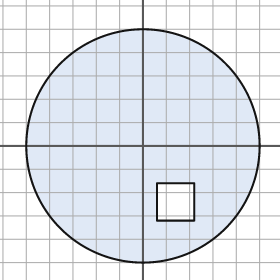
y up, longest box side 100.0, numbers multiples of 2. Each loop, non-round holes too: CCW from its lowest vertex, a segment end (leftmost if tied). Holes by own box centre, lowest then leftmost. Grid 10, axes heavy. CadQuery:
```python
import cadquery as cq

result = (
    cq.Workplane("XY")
    .moveTo(0.0, 0.0)
    .circle(50.0)
    .moveTo(6.0, -32.0)
    .lineTo(22.0, -32.0)
    .lineTo(22.0, -16.0)
    .lineTo(6.0, -16.0)
    .close()
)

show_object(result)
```